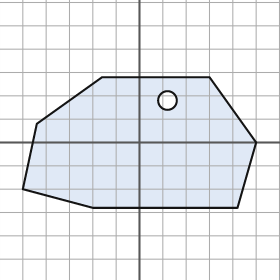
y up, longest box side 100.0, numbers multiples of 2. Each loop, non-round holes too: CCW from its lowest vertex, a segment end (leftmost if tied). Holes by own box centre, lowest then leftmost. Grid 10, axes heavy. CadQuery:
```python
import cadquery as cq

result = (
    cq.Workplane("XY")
    .moveTo(-20.0, -28.0)
    .lineTo(42.0, -28.0)
    .lineTo(50.0, 0.0)
    .lineTo(30.0, 28.0)
    .lineTo(-16.0, 28.0)
    .lineTo(-44.0, 8.0)
    .lineTo(-50.0, -20.0)
    .close()
    .moveTo(12.0, 18.0)
    .circle(4.0)
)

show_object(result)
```